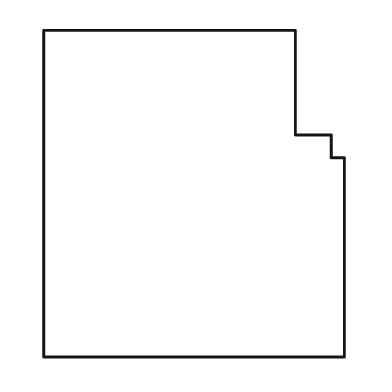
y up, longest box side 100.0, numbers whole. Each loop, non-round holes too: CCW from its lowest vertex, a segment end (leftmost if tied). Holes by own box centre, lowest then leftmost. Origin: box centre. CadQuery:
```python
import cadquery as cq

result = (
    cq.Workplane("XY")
    .moveTo(-46.0, -50.0)
    .lineTo(46.0, -50.0)
    .lineTo(46.0, 11.0)
    .lineTo(42.0, 11.0)
    .lineTo(42.0, 18.0)
    .lineTo(31.0, 18.0)
    .lineTo(31.0, 50.0)
    .lineTo(-46.0, 50.0)
    .close()
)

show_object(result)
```